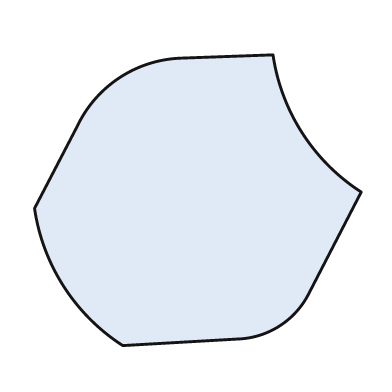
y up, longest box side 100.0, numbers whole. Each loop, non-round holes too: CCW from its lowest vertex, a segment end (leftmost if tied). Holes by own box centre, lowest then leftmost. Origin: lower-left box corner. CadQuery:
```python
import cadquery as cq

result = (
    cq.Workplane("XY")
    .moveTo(27.0, 0.0)
    .lineTo(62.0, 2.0)
    .threePointArc((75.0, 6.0), (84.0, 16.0))
    .lineTo(100.0, 47.0)
    .threePointArc((82.0, 65.0), (73.0, 89.0))
    .lineTo(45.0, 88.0)
    .threePointArc((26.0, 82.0), (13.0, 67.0))
    .lineTo(0.0, 42.0)
    .threePointArc((9.0, 18.0), (27.0, 0.0))
    .close()
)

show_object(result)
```